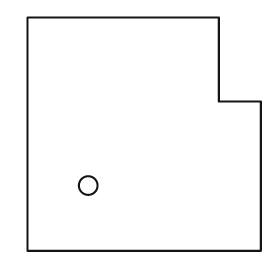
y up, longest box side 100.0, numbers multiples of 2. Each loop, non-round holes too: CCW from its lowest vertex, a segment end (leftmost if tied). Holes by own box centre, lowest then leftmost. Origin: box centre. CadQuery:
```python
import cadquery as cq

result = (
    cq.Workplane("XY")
    .moveTo(-50.0, -50.0)
    .lineTo(50.0, -50.0)
    .lineTo(50.0, 14.0)
    .lineTo(32.0, 14.0)
    .lineTo(32.0, 50.0)
    .lineTo(-50.0, 50.0)
    .close()
    .moveTo(-24.0, -22.0)
    .circle(4.0)
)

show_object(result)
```